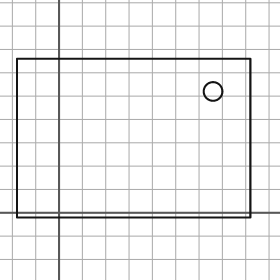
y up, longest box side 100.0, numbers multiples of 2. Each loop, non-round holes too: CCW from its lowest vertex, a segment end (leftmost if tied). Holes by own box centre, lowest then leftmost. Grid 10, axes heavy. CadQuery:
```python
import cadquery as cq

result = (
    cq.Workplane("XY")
    .moveTo(-18.0, -2.0)
    .lineTo(82.0, -2.0)
    .lineTo(82.0, 66.0)
    .lineTo(-18.0, 66.0)
    .close()
    .moveTo(66.0, 52.0)
    .circle(4.0)
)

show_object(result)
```